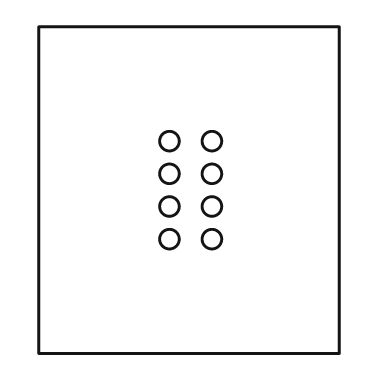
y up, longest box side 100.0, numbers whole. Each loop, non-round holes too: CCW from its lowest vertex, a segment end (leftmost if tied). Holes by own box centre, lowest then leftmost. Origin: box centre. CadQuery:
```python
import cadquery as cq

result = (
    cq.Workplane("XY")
    .moveTo(-46.0, -50.0)
    .lineTo(46.0, -50.0)
    .lineTo(46.0, 50.0)
    .lineTo(-46.0, 50.0)
    .close()
    .moveTo(-6.0, -15.0)
    .circle(3.0)
    .moveTo(7.0, -15.0)
    .circle(3.0)
    .moveTo(-6.0, -5.0)
    .circle(3.0)
    .moveTo(7.0, -5.0)
    .circle(3.0)
    .moveTo(-6.0, 5.0)
    .circle(3.0)
    .moveTo(7.0, 5.0)
    .circle(3.0)
    .moveTo(-6.0, 15.0)
    .circle(3.0)
    .moveTo(7.0, 15.0)
    .circle(3.0)
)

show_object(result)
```